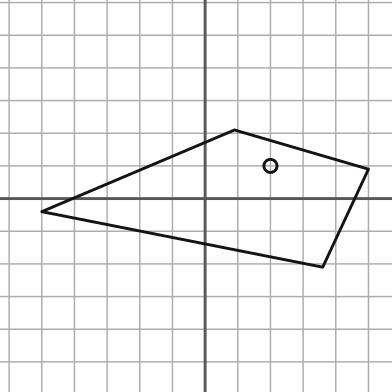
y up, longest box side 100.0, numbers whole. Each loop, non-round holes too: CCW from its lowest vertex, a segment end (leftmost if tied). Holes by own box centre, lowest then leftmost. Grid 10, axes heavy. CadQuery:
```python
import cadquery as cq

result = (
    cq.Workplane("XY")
    .moveTo(36.0, -21.0)
    .lineTo(50.0, 9.0)
    .lineTo(9.0, 21.0)
    .lineTo(-50.0, -4.0)
    .close()
    .moveTo(20.0, 10.0)
    .circle(2.0)
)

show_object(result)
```